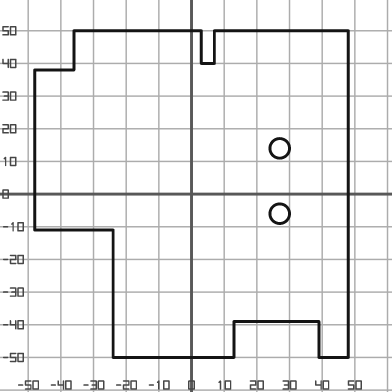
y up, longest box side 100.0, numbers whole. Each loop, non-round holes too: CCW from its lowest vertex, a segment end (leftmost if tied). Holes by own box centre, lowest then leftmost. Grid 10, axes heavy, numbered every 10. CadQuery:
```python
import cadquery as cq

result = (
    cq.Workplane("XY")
    .moveTo(-24.0, -50.0)
    .lineTo(13.0, -50.0)
    .lineTo(13.0, -39.0)
    .lineTo(39.0, -39.0)
    .lineTo(39.0, -50.0)
    .lineTo(48.0, -50.0)
    .lineTo(48.0, 50.0)
    .lineTo(7.0, 50.0)
    .lineTo(7.0, 40.0)
    .lineTo(3.0, 40.0)
    .lineTo(3.0, 50.0)
    .lineTo(-36.0, 50.0)
    .lineTo(-36.0, 38.0)
    .lineTo(-48.0, 38.0)
    .lineTo(-48.0, -11.0)
    .lineTo(-24.0, -11.0)
    .close()
    .moveTo(27.0, -6.0)
    .circle(3.0)
    .moveTo(27.0, 14.0)
    .circle(3.0)
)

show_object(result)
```